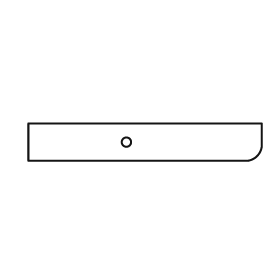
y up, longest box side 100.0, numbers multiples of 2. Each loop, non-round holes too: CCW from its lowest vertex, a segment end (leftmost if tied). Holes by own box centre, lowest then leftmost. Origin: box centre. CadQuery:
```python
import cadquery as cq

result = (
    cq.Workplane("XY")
    .moveTo(-50.0, -8.0)
    .lineTo(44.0, -8.0)
    .threePointArc((48.0, -6.0), (50.0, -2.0))
    .lineTo(50.0, 8.0)
    .lineTo(-50.0, 8.0)
    .close()
    .moveTo(-8.0, 0.0)
    .circle(2.0)
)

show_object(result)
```